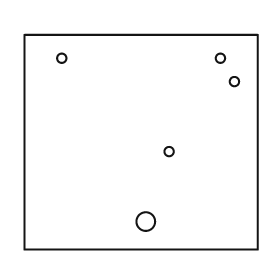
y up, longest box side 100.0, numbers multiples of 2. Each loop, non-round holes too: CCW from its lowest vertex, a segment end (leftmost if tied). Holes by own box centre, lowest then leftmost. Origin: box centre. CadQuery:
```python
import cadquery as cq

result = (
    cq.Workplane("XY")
    .moveTo(-50.0, -46.0)
    .lineTo(50.0, -46.0)
    .lineTo(50.0, 46.0)
    .lineTo(-50.0, 46.0)
    .close()
    .moveTo(2.0, -34.0)
    .circle(4.0)
    .moveTo(12.0, -4.0)
    .circle(2.0)
    .moveTo(40.0, 26.0)
    .circle(2.0)
    .moveTo(-34.0, 36.0)
    .circle(2.0)
    .moveTo(34.0, 36.0)
    .circle(2.0)
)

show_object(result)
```